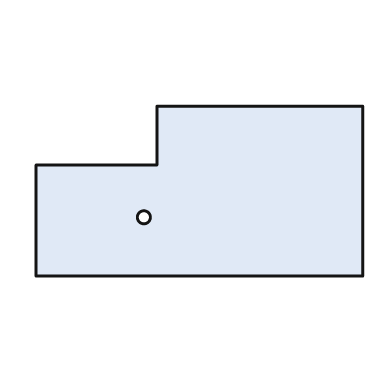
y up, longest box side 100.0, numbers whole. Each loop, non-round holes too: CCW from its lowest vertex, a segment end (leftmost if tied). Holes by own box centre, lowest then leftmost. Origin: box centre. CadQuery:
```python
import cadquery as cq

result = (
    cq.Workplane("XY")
    .moveTo(-50.0, -26.0)
    .lineTo(50.0, -26.0)
    .lineTo(50.0, 26.0)
    .lineTo(-13.0, 26.0)
    .lineTo(-13.0, 8.0)
    .lineTo(-50.0, 8.0)
    .close()
    .moveTo(-17.0, -8.0)
    .circle(2.0)
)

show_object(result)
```